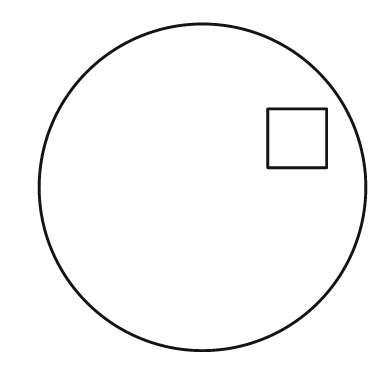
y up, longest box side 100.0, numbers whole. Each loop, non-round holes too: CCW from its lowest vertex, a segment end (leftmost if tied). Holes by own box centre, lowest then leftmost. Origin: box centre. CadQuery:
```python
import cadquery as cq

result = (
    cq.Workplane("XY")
    .moveTo(0.0, 0.0)
    .circle(50.0)
    .moveTo(20.0, 6.0)
    .lineTo(38.0, 6.0)
    .lineTo(38.0, 24.0)
    .lineTo(20.0, 24.0)
    .close()
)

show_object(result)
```